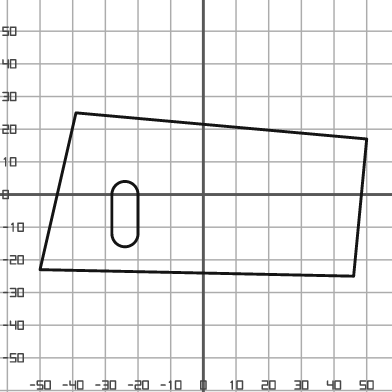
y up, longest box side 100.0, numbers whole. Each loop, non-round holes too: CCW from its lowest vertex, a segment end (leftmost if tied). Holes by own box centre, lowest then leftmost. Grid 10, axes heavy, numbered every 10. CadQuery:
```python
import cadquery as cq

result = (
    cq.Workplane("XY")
    .moveTo(46.0, -25.0)
    .lineTo(50.0, 17.0)
    .lineTo(-39.0, 25.0)
    .lineTo(-50.0, -23.0)
    .close()
    .moveTo(-28.0, -12.0)
    .threePointArc((-24.0, -16.0), (-20.0, -12.0))
    .lineTo(-20.0, 0.0)
    .threePointArc((-24.0, 4.0), (-28.0, 0.0))
    .close()
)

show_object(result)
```